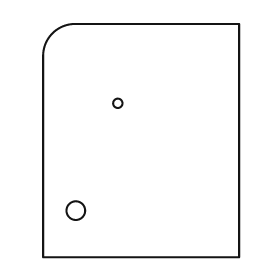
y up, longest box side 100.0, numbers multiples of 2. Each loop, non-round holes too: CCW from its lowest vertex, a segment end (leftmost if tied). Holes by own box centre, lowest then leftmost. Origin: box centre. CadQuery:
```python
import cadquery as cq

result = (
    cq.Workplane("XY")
    .moveTo(-42.0, -50.0)
    .lineTo(42.0, -50.0)
    .lineTo(42.0, 50.0)
    .lineTo(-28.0, 50.0)
    .threePointArc((-38.0, 46.0), (-42.0, 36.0))
    .close()
    .moveTo(-28.0, -30.0)
    .circle(4.0)
    .moveTo(-10.0, 16.0)
    .circle(2.0)
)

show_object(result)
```